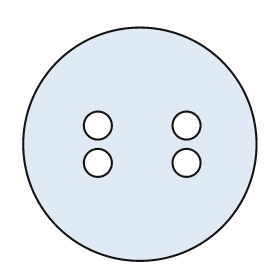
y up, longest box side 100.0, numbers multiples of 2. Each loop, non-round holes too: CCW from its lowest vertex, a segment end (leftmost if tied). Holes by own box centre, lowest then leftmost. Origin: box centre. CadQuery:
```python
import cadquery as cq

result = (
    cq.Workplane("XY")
    .moveTo(0.0, 0.0)
    .circle(50.0)
    .moveTo(-18.0, -8.0)
    .circle(6.0)
    .moveTo(20.0, -8.0)
    .circle(6.0)
    .moveTo(-18.0, 8.0)
    .circle(6.0)
    .moveTo(20.0, 8.0)
    .circle(6.0)
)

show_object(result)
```